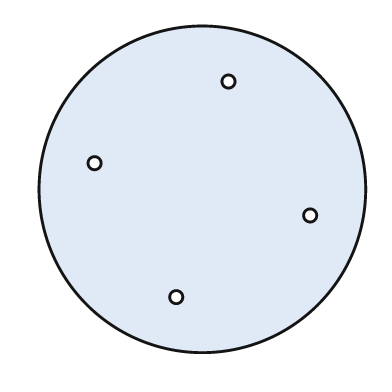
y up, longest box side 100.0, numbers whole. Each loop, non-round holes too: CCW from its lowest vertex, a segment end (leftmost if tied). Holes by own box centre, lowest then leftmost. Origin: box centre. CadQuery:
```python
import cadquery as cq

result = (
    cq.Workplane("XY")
    .moveTo(0.0, 0.0)
    .circle(50.0)
    .moveTo(-8.0, -33.0)
    .circle(2.0)
    .moveTo(33.0, -8.0)
    .circle(2.0)
    .moveTo(-33.0, 8.0)
    .circle(2.0)
    .moveTo(8.0, 33.0)
    .circle(2.0)
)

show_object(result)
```